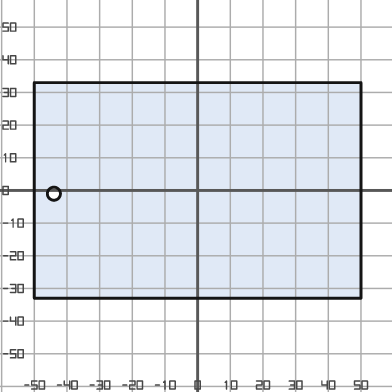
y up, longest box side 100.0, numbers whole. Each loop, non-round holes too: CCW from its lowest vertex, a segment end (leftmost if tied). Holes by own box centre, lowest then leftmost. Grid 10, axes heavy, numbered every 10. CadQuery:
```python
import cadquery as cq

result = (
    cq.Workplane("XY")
    .moveTo(-50.0, -33.0)
    .lineTo(50.0, -33.0)
    .lineTo(50.0, 33.0)
    .lineTo(-50.0, 33.0)
    .close()
    .moveTo(-44.0, -1.0)
    .circle(2.0)
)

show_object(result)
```